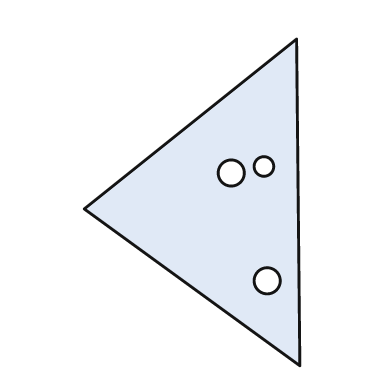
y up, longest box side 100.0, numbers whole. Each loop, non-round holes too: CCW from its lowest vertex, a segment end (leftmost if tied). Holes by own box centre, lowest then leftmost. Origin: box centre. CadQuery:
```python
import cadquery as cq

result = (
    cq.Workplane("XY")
    .moveTo(33.0, -50.0)
    .lineTo(32.0, 50.0)
    .lineTo(-33.0, -2.0)
    .close()
    .moveTo(23.0, -24.0)
    .circle(4.0)
    .moveTo(12.0, 9.0)
    .circle(4.0)
    .moveTo(22.0, 11.0)
    .circle(3.0)
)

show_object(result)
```